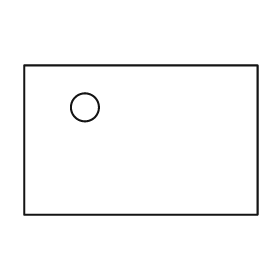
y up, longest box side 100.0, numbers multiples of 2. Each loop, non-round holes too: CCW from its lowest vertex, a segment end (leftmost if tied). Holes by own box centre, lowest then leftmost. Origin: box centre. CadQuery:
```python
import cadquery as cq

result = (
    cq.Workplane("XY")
    .moveTo(-50.0, -32.0)
    .lineTo(50.0, -32.0)
    .lineTo(50.0, 32.0)
    .lineTo(-50.0, 32.0)
    .close()
    .moveTo(-24.0, 14.0)
    .circle(6.0)
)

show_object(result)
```